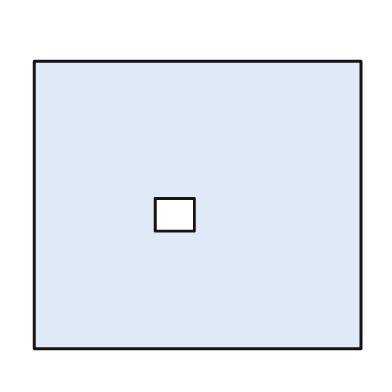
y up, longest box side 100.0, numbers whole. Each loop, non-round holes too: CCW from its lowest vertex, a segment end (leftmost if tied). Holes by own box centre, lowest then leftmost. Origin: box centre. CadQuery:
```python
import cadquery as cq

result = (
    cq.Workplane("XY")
    .moveTo(-50.0, -44.0)
    .lineTo(50.0, -44.0)
    .lineTo(50.0, 44.0)
    .lineTo(-50.0, 44.0)
    .close()
    .moveTo(-13.0, -8.0)
    .lineTo(-1.0, -8.0)
    .lineTo(-1.0, 2.0)
    .lineTo(-13.0, 2.0)
    .close()
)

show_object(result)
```